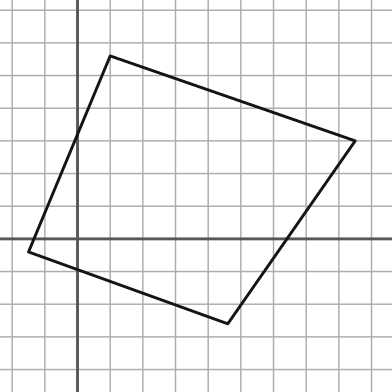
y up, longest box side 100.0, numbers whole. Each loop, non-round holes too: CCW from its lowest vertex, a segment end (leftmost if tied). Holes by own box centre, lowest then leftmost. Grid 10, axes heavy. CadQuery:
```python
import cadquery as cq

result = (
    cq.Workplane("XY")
    .moveTo(46.0, -26.0)
    .lineTo(85.0, 30.0)
    .lineTo(10.0, 56.0)
    .lineTo(-15.0, -4.0)
    .close()
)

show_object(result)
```